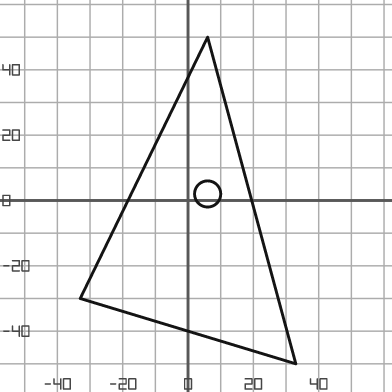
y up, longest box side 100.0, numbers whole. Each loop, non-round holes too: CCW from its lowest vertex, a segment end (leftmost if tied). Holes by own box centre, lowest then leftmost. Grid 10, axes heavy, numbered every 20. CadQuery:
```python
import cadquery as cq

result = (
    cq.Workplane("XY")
    .moveTo(33.0, -50.0)
    .lineTo(6.0, 50.0)
    .lineTo(-33.0, -30.0)
    .close()
    .moveTo(6.0, 2.0)
    .circle(4.0)
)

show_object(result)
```